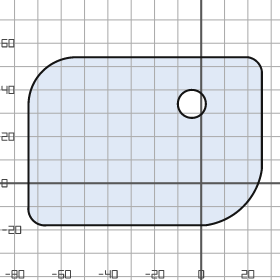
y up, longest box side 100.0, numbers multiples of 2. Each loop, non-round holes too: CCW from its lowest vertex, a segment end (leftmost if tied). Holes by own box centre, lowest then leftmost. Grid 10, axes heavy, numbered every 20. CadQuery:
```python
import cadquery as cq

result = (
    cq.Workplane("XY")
    .moveTo(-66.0, -18.0)
    .lineTo(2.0, -18.0)
    .threePointArc((18.0, -10.0), (26.0, 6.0))
    .lineTo(26.0, 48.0)
    .threePointArc((24.0, 52.0), (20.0, 54.0))
    .lineTo(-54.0, 54.0)
    .threePointArc((-68.0, 48.0), (-74.0, 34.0))
    .lineTo(-74.0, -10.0)
    .threePointArc((-72.0, -16.0), (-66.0, -18.0))
    .close()
    .moveTo(-4.0, 34.0)
    .circle(6.0)
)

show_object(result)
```